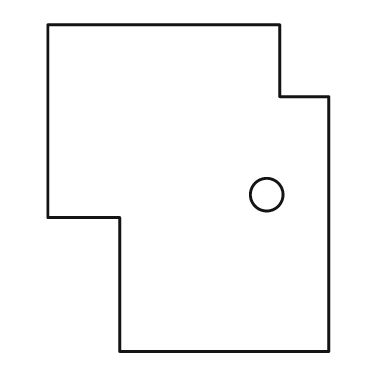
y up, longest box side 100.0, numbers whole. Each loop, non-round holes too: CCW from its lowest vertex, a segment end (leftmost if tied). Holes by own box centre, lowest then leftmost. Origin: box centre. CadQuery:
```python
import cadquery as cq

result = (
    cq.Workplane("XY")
    .moveTo(-21.0, -50.0)
    .lineTo(43.0, -50.0)
    .lineTo(43.0, 28.0)
    .lineTo(28.0, 28.0)
    .lineTo(28.0, 50.0)
    .lineTo(-43.0, 50.0)
    .lineTo(-43.0, -9.0)
    .lineTo(-21.0, -9.0)
    .close()
    .moveTo(24.0, -2.0)
    .circle(5.0)
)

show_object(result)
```